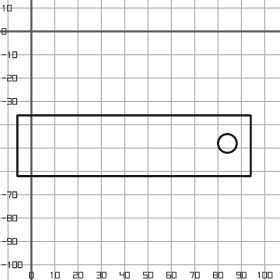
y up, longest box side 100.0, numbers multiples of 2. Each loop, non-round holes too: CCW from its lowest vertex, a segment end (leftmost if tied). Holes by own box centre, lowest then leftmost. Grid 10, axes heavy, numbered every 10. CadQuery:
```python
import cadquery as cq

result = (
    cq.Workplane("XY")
    .moveTo(-6.0, -62.0)
    .lineTo(94.0, -62.0)
    .lineTo(94.0, -36.0)
    .lineTo(-6.0, -36.0)
    .close()
    .moveTo(84.0, -48.0)
    .circle(4.0)
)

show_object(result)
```